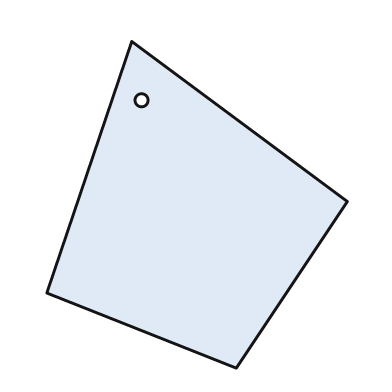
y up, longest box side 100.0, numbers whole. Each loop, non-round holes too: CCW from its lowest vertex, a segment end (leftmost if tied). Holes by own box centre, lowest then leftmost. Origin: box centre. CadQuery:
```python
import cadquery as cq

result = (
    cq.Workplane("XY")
    .moveTo(12.0, -50.0)
    .lineTo(46.0, 1.0)
    .lineTo(-20.0, 50.0)
    .lineTo(-46.0, -27.0)
    .close()
    .moveTo(-17.0, 32.0)
    .circle(2.0)
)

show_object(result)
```